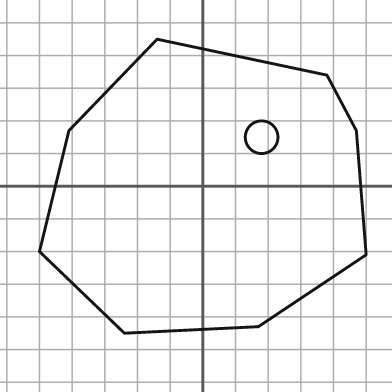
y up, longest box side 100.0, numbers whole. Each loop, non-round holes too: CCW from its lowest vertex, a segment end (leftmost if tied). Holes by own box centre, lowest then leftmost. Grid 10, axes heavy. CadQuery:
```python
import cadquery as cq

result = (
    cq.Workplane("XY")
    .moveTo(-24.0, -45.0)
    .lineTo(17.0, -43.0)
    .lineTo(50.0, -21.0)
    .lineTo(47.0, 17.0)
    .lineTo(38.0, 34.0)
    .lineTo(-14.0, 45.0)
    .lineTo(-41.0, 17.0)
    .lineTo(-50.0, -20.0)
    .close()
    .moveTo(18.0, 15.0)
    .circle(5.0)
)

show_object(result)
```